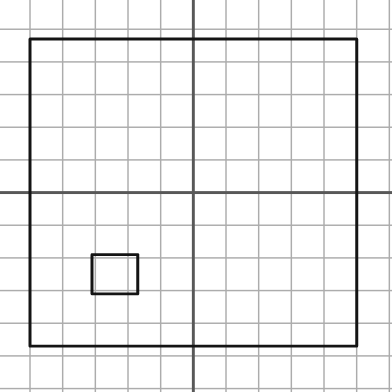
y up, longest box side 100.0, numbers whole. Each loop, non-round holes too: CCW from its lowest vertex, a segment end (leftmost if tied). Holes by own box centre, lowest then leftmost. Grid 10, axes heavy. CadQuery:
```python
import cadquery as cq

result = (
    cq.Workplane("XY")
    .moveTo(-50.0, -47.0)
    .lineTo(50.0, -47.0)
    .lineTo(50.0, 47.0)
    .lineTo(-50.0, 47.0)
    .close()
    .moveTo(-31.0, -31.0)
    .lineTo(-17.0, -31.0)
    .lineTo(-17.0, -19.0)
    .lineTo(-31.0, -19.0)
    .close()
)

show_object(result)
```